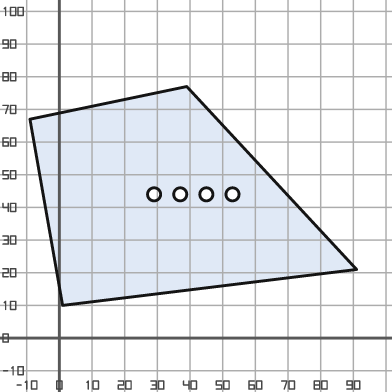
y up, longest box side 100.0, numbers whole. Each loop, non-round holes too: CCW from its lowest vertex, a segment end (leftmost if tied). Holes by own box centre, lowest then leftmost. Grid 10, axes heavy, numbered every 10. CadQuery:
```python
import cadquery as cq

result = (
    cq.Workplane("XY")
    .moveTo(1.0, 10.0)
    .lineTo(91.0, 21.0)
    .lineTo(39.0, 77.0)
    .lineTo(-9.0, 67.0)
    .close()
    .moveTo(29.0, 44.0)
    .circle(2.0)
    .moveTo(37.0, 44.0)
    .circle(2.0)
    .moveTo(45.0, 44.0)
    .circle(2.0)
    .moveTo(53.0, 44.0)
    .circle(2.0)
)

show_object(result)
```